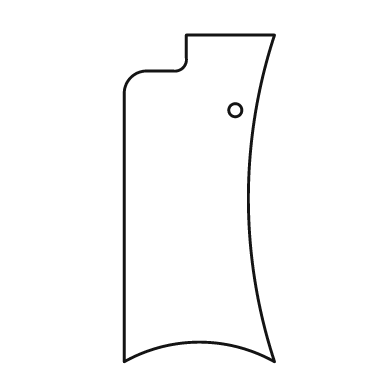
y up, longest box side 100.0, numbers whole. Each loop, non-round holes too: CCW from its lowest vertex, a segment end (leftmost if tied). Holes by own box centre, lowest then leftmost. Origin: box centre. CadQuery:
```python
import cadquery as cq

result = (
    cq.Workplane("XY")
    .moveTo(-23.0, -50.0)
    .threePointArc((0.0, -44.0), (23.0, -50.0))
    .threePointArc((15.0, 0.0), (23.0, 50.0))
    .lineTo(-4.0, 50.0)
    .lineTo(-4.0, 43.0)
    .threePointArc((-5.0, 40.0), (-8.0, 39.0))
    .lineTo(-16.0, 39.0)
    .threePointArc((-21.0, 37.0), (-23.0, 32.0))
    .close()
    .moveTo(11.0, 27.0)
    .circle(2.0)
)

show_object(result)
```